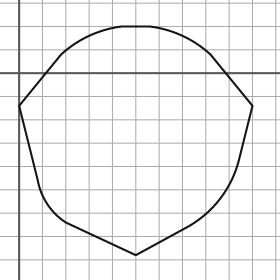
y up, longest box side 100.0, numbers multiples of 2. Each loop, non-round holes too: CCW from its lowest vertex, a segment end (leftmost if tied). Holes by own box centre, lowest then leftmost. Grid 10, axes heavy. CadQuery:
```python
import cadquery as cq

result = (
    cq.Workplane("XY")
    .moveTo(50.0, -78.0)
    .lineTo(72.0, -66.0)
    .threePointArc((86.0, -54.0), (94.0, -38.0))
    .lineTo(100.0, -14.0)
    .lineTo(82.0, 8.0)
    .threePointArc((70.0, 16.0), (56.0, 20.0))
    .lineTo(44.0, 20.0)
    .threePointArc((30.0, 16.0), (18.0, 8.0))
    .lineTo(0.0, -14.0)
    .lineTo(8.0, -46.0)
    .threePointArc((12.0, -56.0), (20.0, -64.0))
    .close()
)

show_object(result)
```